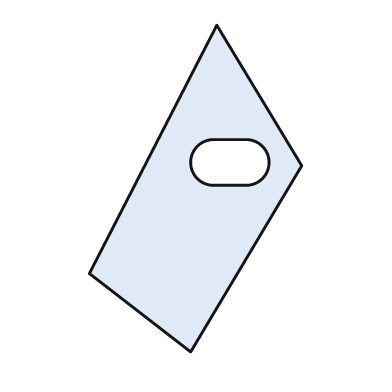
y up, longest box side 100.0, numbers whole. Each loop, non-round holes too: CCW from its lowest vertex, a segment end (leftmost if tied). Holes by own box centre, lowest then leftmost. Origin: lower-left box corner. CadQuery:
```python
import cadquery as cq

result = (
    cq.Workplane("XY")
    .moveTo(31.0, 0.0)
    .lineTo(65.0, 57.0)
    .lineTo(39.0, 100.0)
    .lineTo(0.0, 24.0)
    .close()
    .moveTo(38.0, 51.0)
    .lineTo(48.0, 51.0)
    .threePointArc((55.0, 58.0), (48.0, 65.0))
    .lineTo(38.0, 65.0)
    .threePointArc((31.0, 58.0), (38.0, 51.0))
    .close()
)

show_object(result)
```